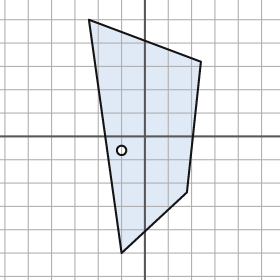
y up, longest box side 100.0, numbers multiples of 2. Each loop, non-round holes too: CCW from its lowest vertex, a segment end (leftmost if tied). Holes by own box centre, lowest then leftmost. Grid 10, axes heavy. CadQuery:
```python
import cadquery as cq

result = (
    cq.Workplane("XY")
    .moveTo(-10.0, -50.0)
    .lineTo(18.0, -24.0)
    .lineTo(24.0, 32.0)
    .lineTo(-24.0, 50.0)
    .close()
    .moveTo(-10.0, -6.0)
    .circle(2.0)
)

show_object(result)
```